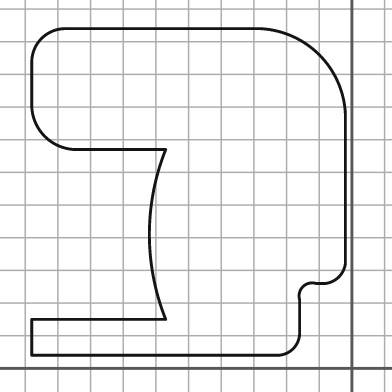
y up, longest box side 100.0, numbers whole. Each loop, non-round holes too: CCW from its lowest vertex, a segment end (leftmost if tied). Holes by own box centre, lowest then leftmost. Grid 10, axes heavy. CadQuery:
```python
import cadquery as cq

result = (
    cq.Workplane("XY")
    .moveTo(-98.0, 4.0)
    .lineTo(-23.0, 4.0)
    .threePointArc((-18.0, 6.0), (-16.0, 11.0))
    .lineTo(-16.0, 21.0)
    .threePointArc((-15.0, 25.0), (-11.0, 26.0))
    .lineTo(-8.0, 26.0)
    .threePointArc((-4.0, 28.0), (-2.0, 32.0))
    .lineTo(-2.0, 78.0)
    .threePointArc((-10.0, 96.0), (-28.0, 104.0))
    .lineTo(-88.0, 104.0)
    .threePointArc((-95.0, 101.0), (-98.0, 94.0))
    .lineTo(-98.0, 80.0)
    .threePointArc((-94.0, 71.0), (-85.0, 67.0))
    .lineTo(-57.0, 67.0)
    .threePointArc((-62.0, 41.0), (-57.0, 15.0))
    .lineTo(-98.0, 15.0)
    .close()
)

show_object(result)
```